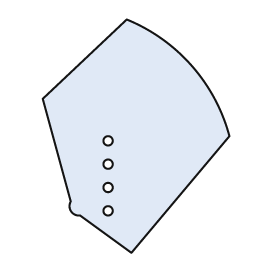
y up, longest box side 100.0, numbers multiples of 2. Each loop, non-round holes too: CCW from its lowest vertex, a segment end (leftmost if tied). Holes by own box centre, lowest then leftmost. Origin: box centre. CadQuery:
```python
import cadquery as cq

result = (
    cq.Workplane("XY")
    .moveTo(-2.0, -50.0)
    .lineTo(40.0, 0.0)
    .threePointArc((24.0, 30.0), (-4.0, 50.0))
    .lineTo(-40.0, 16.0)
    .lineTo(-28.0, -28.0)
    .threePointArc((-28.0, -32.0), (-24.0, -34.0))
    .close()
    .moveTo(-12.0, -32.0)
    .circle(2.0)
    .moveTo(-12.0, -22.0)
    .circle(2.0)
    .moveTo(-12.0, -12.0)
    .circle(2.0)
    .moveTo(-12.0, -2.0)
    .circle(2.0)
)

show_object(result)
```